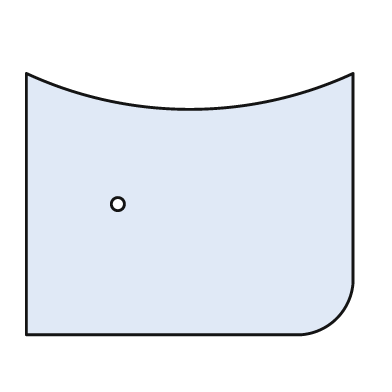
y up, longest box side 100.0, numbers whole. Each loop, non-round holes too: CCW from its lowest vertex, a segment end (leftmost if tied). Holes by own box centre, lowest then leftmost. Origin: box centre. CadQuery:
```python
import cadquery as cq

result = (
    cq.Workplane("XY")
    .moveTo(-50.0, -40.0)
    .lineTo(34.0, -40.0)
    .threePointArc((45.0, -35.0), (50.0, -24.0))
    .lineTo(50.0, 40.0)
    .threePointArc((0.0, 29.0), (-50.0, 40.0))
    .close()
    .moveTo(-22.0, 0.0)
    .circle(2.0)
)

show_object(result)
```